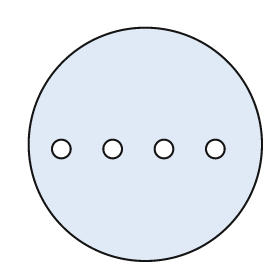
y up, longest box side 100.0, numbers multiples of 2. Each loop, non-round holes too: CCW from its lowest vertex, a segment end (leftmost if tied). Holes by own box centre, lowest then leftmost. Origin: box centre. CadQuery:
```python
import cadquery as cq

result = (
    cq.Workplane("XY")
    .moveTo(0.0, 0.0)
    .circle(50.0)
    .moveTo(-36.0, -2.0)
    .circle(4.0)
    .moveTo(-14.0, -2.0)
    .circle(4.0)
    .moveTo(8.0, -2.0)
    .circle(4.0)
    .moveTo(30.0, -2.0)
    .circle(4.0)
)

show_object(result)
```